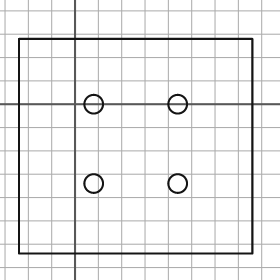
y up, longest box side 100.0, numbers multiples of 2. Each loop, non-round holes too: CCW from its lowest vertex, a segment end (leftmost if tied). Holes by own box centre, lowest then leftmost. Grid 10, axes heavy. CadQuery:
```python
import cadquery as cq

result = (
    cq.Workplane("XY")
    .moveTo(-24.0, -64.0)
    .lineTo(76.0, -64.0)
    .lineTo(76.0, 28.0)
    .lineTo(-24.0, 28.0)
    .close()
    .moveTo(8.0, -34.0)
    .circle(4.0)
    .moveTo(44.0, -34.0)
    .circle(4.0)
    .moveTo(8.0, 0.0)
    .circle(4.0)
    .moveTo(44.0, 0.0)
    .circle(4.0)
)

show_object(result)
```